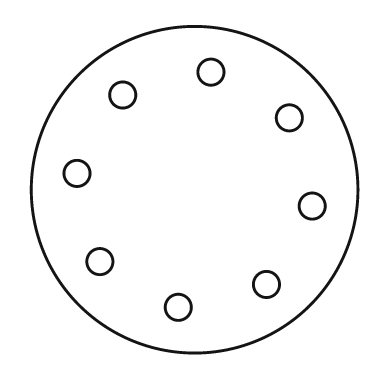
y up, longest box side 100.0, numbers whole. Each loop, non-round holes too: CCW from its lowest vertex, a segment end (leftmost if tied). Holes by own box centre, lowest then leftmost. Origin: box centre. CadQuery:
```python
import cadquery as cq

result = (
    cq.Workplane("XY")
    .moveTo(0.0, 0.0)
    .circle(50.0)
    .moveTo(-5.0, -36.0)
    .circle(4.0)
    .moveTo(22.0, -29.0)
    .circle(4.0)
    .moveTo(-29.0, -22.0)
    .circle(4.0)
    .moveTo(36.0, -5.0)
    .circle(4.0)
    .moveTo(-36.0, 5.0)
    .circle(4.0)
    .moveTo(29.0, 22.0)
    .circle(4.0)
    .moveTo(-22.0, 29.0)
    .circle(4.0)
    .moveTo(5.0, 36.0)
    .circle(4.0)
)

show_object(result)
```